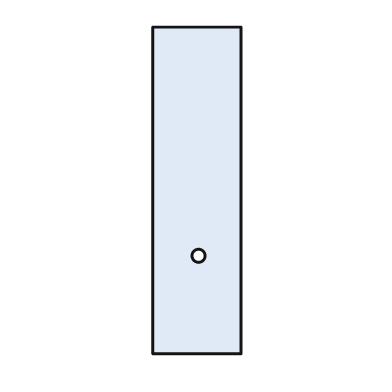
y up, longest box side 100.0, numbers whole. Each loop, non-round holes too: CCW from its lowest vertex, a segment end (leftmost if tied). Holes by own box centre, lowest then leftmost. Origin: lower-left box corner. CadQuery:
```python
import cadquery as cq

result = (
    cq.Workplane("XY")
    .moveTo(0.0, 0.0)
    .lineTo(27.0, 0.0)
    .lineTo(27.0, 100.0)
    .lineTo(0.0, 100.0)
    .close()
    .moveTo(14.0, 30.0)
    .circle(2.0)
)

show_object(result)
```